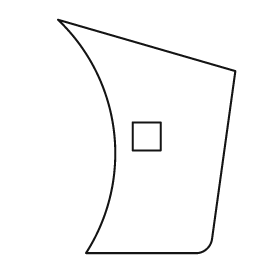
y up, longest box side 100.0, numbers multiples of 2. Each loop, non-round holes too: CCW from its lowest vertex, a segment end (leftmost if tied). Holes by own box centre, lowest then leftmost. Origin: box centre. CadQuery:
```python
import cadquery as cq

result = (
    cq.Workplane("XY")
    .moveTo(-26.0, -50.0)
    .lineTo(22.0, -50.0)
    .threePointArc((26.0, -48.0), (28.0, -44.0))
    .lineTo(38.0, 28.0)
    .lineTo(-38.0, 50.0)
    .threePointArc((-14.0, 2.0), (-26.0, -50.0))
    .close()
    .moveTo(-6.0, -6.0)
    .lineTo(6.0, -6.0)
    .lineTo(6.0, 6.0)
    .lineTo(-6.0, 6.0)
    .close()
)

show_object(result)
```